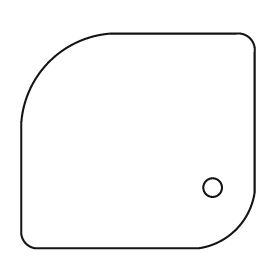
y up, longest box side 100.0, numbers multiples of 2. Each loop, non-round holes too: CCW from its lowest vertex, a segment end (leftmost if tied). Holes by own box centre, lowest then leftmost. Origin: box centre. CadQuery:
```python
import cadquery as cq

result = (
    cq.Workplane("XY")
    .moveTo(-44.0, -46.0)
    .lineTo(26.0, -46.0)
    .threePointArc((42.0, -38.0), (50.0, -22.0))
    .lineTo(50.0, 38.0)
    .threePointArc((48.0, 44.0), (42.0, 46.0))
    .lineTo(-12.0, 46.0)
    .threePointArc((-38.0, 34.0), (-50.0, 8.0))
    .lineTo(-50.0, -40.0)
    .threePointArc((-48.0, -44.0), (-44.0, -46.0))
    .close()
    .moveTo(32.0, -20.0)
    .circle(4.0)
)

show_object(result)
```